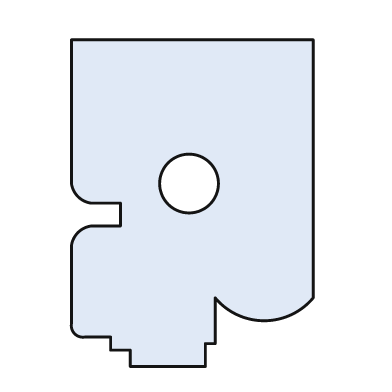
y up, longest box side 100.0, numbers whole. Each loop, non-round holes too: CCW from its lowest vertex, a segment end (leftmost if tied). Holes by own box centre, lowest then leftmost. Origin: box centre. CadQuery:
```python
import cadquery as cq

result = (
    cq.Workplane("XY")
    .moveTo(-19.0, -50.0)
    .lineTo(4.0, -50.0)
    .lineTo(4.0, -43.0)
    .lineTo(7.0, -43.0)
    .lineTo(7.0, -29.0)
    .threePointArc((22.0, -36.0), (37.0, -29.0))
    .lineTo(37.0, 50.0)
    .lineTo(-37.0, 50.0)
    .lineTo(-37.0, 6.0)
    .threePointArc((-35.0, 2.0), (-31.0, 0.0))
    .lineTo(-22.0, 0.0)
    .lineTo(-22.0, -7.0)
    .lineTo(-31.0, -7.0)
    .threePointArc((-35.0, -9.0), (-37.0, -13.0))
    .lineTo(-37.0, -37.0)
    .threePointArc((-36.0, -40.0), (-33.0, -41.0))
    .lineTo(-25.0, -41.0)
    .lineTo(-25.0, -45.0)
    .lineTo(-19.0, -45.0)
    .close()
    .moveTo(-1.0, 6.0)
    .circle(9.0)
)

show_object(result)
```